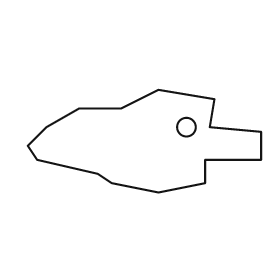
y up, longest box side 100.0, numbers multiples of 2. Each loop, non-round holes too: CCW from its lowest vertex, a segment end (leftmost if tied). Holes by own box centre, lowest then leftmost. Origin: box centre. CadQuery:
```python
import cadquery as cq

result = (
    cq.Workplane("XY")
    .moveTo(6.0, -22.0)
    .lineTo(26.0, -18.0)
    .lineTo(26.0, -8.0)
    .lineTo(50.0, -8.0)
    .lineTo(50.0, 4.0)
    .lineTo(28.0, 6.0)
    .lineTo(30.0, 18.0)
    .lineTo(6.0, 22.0)
    .lineTo(-10.0, 14.0)
    .lineTo(-28.0, 14.0)
    .lineTo(-42.0, 6.0)
    .lineTo(-50.0, -2.0)
    .lineTo(-46.0, -8.0)
    .lineTo(-20.0, -14.0)
    .lineTo(-14.0, -18.0)
    .close()
    .moveTo(18.0, 6.0)
    .circle(4.0)
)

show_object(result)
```